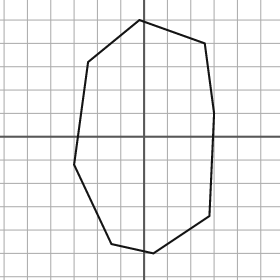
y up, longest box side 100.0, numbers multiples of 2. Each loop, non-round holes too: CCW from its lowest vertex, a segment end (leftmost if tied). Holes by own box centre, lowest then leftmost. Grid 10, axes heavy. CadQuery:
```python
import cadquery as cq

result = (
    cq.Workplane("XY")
    .moveTo(4.0, -50.0)
    .lineTo(28.0, -34.0)
    .lineTo(30.0, 10.0)
    .lineTo(26.0, 40.0)
    .lineTo(-2.0, 50.0)
    .lineTo(-24.0, 32.0)
    .lineTo(-30.0, -12.0)
    .lineTo(-14.0, -46.0)
    .close()
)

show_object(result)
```